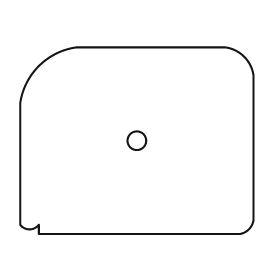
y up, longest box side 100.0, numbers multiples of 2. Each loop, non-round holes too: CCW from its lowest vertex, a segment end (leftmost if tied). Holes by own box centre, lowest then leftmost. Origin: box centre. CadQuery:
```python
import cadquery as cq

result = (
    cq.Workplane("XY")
    .moveTo(-42.0, -40.0)
    .lineTo(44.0, -40.0)
    .threePointArc((48.0, -38.0), (50.0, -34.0))
    .lineTo(50.0, 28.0)
    .threePointArc((46.0, 36.0), (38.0, 40.0))
    .lineTo(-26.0, 40.0)
    .threePointArc((-42.0, 32.0), (-50.0, 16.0))
    .lineTo(-50.0, -36.0)
    .threePointArc((-46.0, -38.0), (-42.0, -36.0))
    .close()
    .moveTo(0.0, 0.0)
    .circle(4.0)
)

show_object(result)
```